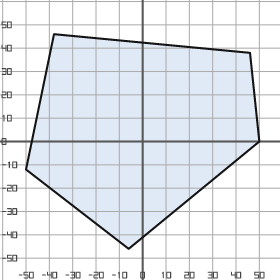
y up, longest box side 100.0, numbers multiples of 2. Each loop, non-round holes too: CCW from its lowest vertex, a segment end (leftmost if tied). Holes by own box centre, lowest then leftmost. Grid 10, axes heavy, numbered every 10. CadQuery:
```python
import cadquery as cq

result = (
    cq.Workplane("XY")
    .moveTo(-6.0, -46.0)
    .lineTo(50.0, 0.0)
    .lineTo(46.0, 38.0)
    .lineTo(-38.0, 46.0)
    .lineTo(-50.0, -12.0)
    .close()
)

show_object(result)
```